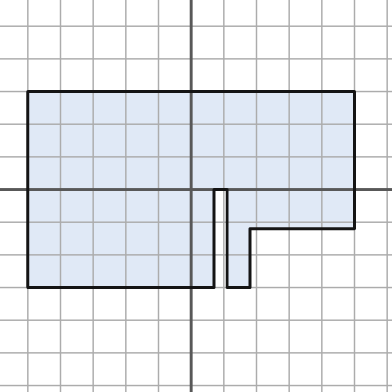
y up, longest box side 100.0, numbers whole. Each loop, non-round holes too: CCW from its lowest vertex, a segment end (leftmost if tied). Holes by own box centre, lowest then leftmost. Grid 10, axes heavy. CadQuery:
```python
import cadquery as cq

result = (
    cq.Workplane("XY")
    .moveTo(-50.0, -30.0)
    .lineTo(7.0, -30.0)
    .lineTo(7.0, 0.0)
    .lineTo(11.0, 0.0)
    .lineTo(11.0, -30.0)
    .lineTo(18.0, -30.0)
    .lineTo(18.0, -12.0)
    .lineTo(50.0, -12.0)
    .lineTo(50.0, 30.0)
    .lineTo(-50.0, 30.0)
    .close()
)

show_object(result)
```